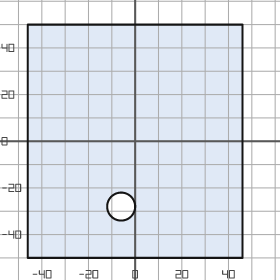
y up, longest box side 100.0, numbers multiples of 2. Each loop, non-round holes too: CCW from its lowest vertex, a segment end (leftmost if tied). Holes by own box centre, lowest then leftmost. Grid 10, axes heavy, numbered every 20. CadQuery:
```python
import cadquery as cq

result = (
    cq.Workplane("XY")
    .moveTo(-46.0, -50.0)
    .lineTo(46.0, -50.0)
    .lineTo(46.0, 50.0)
    .lineTo(-46.0, 50.0)
    .close()
    .moveTo(-6.0, -28.0)
    .circle(6.0)
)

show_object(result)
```